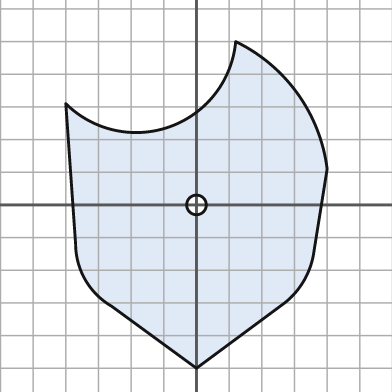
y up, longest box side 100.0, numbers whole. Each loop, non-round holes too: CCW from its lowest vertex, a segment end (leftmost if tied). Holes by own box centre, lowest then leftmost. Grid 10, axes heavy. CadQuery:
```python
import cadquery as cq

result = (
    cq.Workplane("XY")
    .moveTo(0.0, -50.0)
    .lineTo(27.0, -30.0)
    .threePointArc((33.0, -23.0), (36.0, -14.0))
    .lineTo(40.0, 11.0)
    .threePointArc((31.0, 34.0), (12.0, 50.0))
    .threePointArc((-8.0, 24.0), (-40.0, 31.0))
    .lineTo(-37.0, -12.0)
    .threePointArc((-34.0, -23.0), (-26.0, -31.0))
    .close()
    .moveTo(0.0, 0.0)
    .circle(3.0)
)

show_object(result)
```